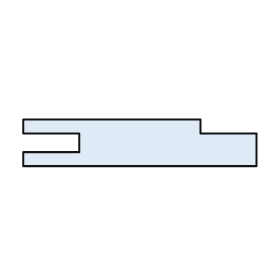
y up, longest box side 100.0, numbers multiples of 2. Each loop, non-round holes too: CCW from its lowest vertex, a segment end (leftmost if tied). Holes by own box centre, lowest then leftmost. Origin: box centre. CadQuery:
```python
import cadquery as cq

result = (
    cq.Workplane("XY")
    .moveTo(-50.0, -10.0)
    .lineTo(50.0, -10.0)
    .lineTo(50.0, 4.0)
    .lineTo(26.0, 4.0)
    .lineTo(26.0, 10.0)
    .lineTo(-50.0, 10.0)
    .lineTo(-50.0, 4.0)
    .lineTo(-26.0, 4.0)
    .lineTo(-26.0, -4.0)
    .lineTo(-50.0, -4.0)
    .close()
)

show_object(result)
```